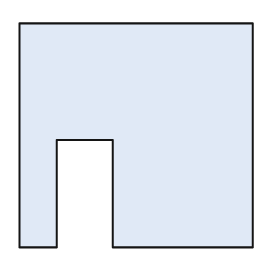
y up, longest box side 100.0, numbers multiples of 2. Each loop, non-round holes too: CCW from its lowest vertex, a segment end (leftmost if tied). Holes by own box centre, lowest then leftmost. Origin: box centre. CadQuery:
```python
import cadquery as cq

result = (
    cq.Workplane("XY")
    .moveTo(-50.0, -48.0)
    .lineTo(-34.0, -48.0)
    .lineTo(-34.0, -2.0)
    .lineTo(-10.0, -2.0)
    .lineTo(-10.0, -48.0)
    .lineTo(50.0, -48.0)
    .lineTo(50.0, 48.0)
    .lineTo(-50.0, 48.0)
    .close()
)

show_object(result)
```